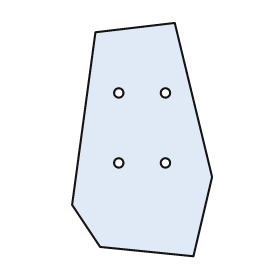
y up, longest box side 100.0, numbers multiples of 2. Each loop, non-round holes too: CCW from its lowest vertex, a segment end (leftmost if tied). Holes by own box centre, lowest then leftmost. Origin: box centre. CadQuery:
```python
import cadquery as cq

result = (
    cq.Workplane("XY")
    .moveTo(22.0, -50.0)
    .lineTo(30.0, -16.0)
    .lineTo(14.0, 50.0)
    .lineTo(-20.0, 46.0)
    .lineTo(-30.0, -28.0)
    .lineTo(-18.0, -46.0)
    .close()
    .moveTo(-10.0, -10.0)
    .circle(2.0)
    .moveTo(10.0, -10.0)
    .circle(2.0)
    .moveTo(-10.0, 20.0)
    .circle(2.0)
    .moveTo(10.0, 20.0)
    .circle(2.0)
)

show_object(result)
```